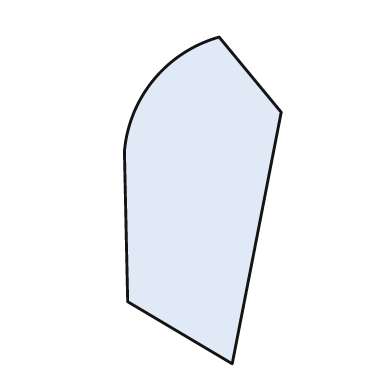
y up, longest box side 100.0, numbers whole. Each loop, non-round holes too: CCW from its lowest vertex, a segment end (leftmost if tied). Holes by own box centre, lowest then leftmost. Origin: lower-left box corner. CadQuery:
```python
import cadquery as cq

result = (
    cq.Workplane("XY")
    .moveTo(33.0, 0.0)
    .lineTo(48.0, 77.0)
    .lineTo(29.0, 100.0)
    .threePointArc((9.0, 87.0), (0.0, 65.0))
    .lineTo(1.0, 19.0)
    .close()
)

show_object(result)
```